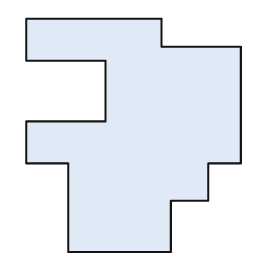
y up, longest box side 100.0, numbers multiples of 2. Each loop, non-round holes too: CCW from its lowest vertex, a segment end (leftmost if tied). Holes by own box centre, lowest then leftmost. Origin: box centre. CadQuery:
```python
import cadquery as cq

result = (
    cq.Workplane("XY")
    .moveTo(-28.0, -50.0)
    .lineTo(16.0, -50.0)
    .lineTo(16.0, -28.0)
    .lineTo(32.0, -28.0)
    .lineTo(32.0, -12.0)
    .lineTo(46.0, -12.0)
    .lineTo(46.0, 38.0)
    .lineTo(12.0, 38.0)
    .lineTo(12.0, 50.0)
    .lineTo(-46.0, 50.0)
    .lineTo(-46.0, 32.0)
    .lineTo(-12.0, 32.0)
    .lineTo(-12.0, 6.0)
    .lineTo(-46.0, 6.0)
    .lineTo(-46.0, -12.0)
    .lineTo(-28.0, -12.0)
    .close()
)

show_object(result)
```